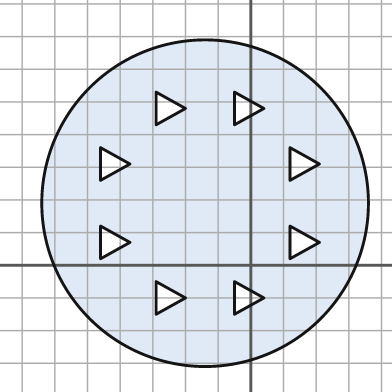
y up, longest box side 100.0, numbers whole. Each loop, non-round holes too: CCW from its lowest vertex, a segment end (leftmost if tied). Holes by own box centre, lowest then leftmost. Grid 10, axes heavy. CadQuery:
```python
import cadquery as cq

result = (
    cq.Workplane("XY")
    .moveTo(-14.0, 19.0)
    .circle(50.0)
    .moveTo(-29.0, -15.0)
    .lineTo(-20.0, -10.0)
    .lineTo(-29.0, -5.0)
    .close()
    .moveTo(-5.0, -15.0)
    .lineTo(4.0, -10.0)
    .lineTo(-5.0, -5.0)
    .close()
    .moveTo(-46.0, 2.0)
    .lineTo(-37.0, 7.0)
    .lineTo(-46.0, 12.0)
    .close()
    .moveTo(12.0, 2.0)
    .lineTo(21.0, 7.0)
    .lineTo(12.0, 12.0)
    .close()
    .moveTo(-46.0, 26.0)
    .lineTo(-37.0, 31.0)
    .lineTo(-46.0, 36.0)
    .close()
    .moveTo(12.0, 26.0)
    .lineTo(21.0, 31.0)
    .lineTo(12.0, 36.0)
    .close()
    .moveTo(-29.0, 43.0)
    .lineTo(-20.0, 48.0)
    .lineTo(-29.0, 53.0)
    .close()
    .moveTo(-5.0, 43.0)
    .lineTo(4.0, 48.0)
    .lineTo(-5.0, 53.0)
    .close()
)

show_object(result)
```